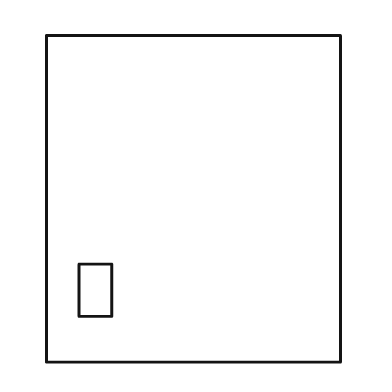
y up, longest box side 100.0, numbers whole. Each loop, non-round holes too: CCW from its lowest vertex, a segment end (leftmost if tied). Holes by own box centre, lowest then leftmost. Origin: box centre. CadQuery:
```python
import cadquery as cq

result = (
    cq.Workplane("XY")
    .moveTo(-45.0, -50.0)
    .lineTo(45.0, -50.0)
    .lineTo(45.0, 50.0)
    .lineTo(-45.0, 50.0)
    .close()
    .moveTo(-35.0, -36.0)
    .lineTo(-25.0, -36.0)
    .lineTo(-25.0, -20.0)
    .lineTo(-35.0, -20.0)
    .close()
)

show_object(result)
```